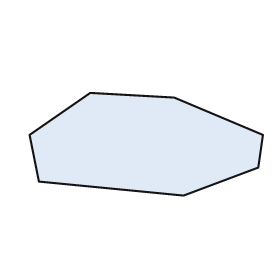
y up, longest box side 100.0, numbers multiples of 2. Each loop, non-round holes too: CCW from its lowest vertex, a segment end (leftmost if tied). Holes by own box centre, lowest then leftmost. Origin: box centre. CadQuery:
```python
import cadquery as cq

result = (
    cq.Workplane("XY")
    .moveTo(16.0, -22.0)
    .lineTo(48.0, -10.0)
    .lineTo(50.0, 4.0)
    .lineTo(12.0, 20.0)
    .lineTo(-24.0, 22.0)
    .lineTo(-50.0, 4.0)
    .lineTo(-46.0, -16.0)
    .close()
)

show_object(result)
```